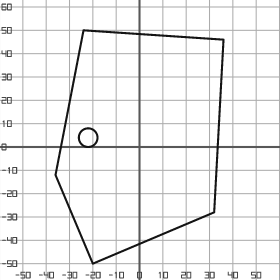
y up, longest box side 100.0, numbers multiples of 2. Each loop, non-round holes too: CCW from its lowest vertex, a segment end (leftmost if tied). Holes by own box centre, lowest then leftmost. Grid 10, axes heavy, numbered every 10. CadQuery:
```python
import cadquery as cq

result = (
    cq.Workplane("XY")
    .moveTo(-20.0, -50.0)
    .lineTo(32.0, -28.0)
    .lineTo(36.0, 46.0)
    .lineTo(-24.0, 50.0)
    .lineTo(-36.0, -12.0)
    .close()
    .moveTo(-22.0, 4.0)
    .circle(4.0)
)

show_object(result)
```